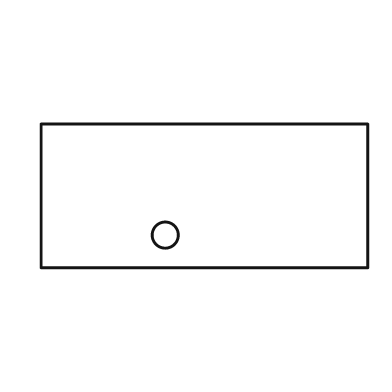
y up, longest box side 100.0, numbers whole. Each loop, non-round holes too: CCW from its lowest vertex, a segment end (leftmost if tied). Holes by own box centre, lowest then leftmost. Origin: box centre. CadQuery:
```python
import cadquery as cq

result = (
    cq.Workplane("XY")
    .moveTo(-50.0, -22.0)
    .lineTo(50.0, -22.0)
    .lineTo(50.0, 22.0)
    .lineTo(-50.0, 22.0)
    .close()
    .moveTo(-12.0, -12.0)
    .circle(4.0)
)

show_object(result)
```